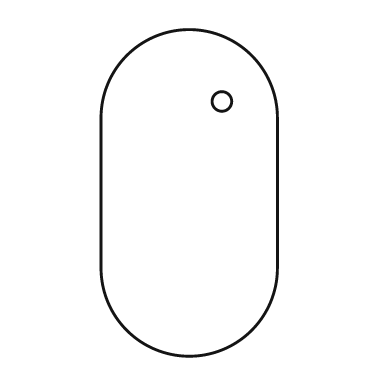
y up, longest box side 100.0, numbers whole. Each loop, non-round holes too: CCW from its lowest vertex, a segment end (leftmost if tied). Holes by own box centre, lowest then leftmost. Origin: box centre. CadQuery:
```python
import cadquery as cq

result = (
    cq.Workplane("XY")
    .moveTo(-27.0, -23.0)
    .threePointArc((0.0, -50.0), (27.0, -23.0))
    .lineTo(27.0, 23.0)
    .threePointArc((0.0, 50.0), (-27.0, 23.0))
    .close()
    .moveTo(10.0, 28.0)
    .circle(3.0)
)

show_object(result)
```